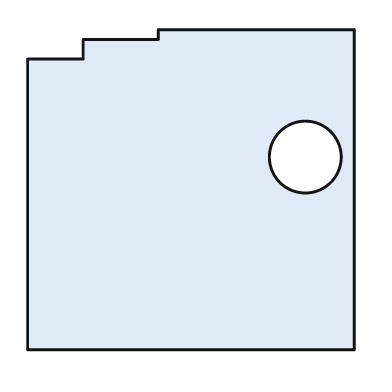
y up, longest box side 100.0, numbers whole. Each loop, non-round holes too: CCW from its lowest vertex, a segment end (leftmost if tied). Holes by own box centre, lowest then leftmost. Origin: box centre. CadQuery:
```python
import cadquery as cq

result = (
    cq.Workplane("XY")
    .moveTo(-50.0, -49.0)
    .lineTo(50.0, -49.0)
    .lineTo(50.0, 49.0)
    .lineTo(-10.0, 49.0)
    .lineTo(-10.0, 46.0)
    .lineTo(-33.0, 46.0)
    .lineTo(-33.0, 40.0)
    .lineTo(-50.0, 40.0)
    .close()
    .moveTo(35.0, 10.0)
    .circle(11.0)
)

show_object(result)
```